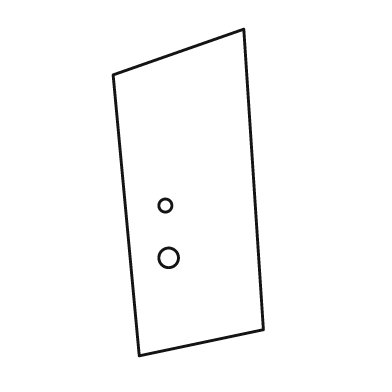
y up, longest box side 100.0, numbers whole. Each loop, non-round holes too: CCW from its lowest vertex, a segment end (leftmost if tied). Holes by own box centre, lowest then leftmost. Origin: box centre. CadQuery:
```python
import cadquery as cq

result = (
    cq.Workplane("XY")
    .moveTo(-15.0, -50.0)
    .lineTo(23.0, -42.0)
    .lineTo(17.0, 50.0)
    .lineTo(-23.0, 36.0)
    .close()
    .moveTo(-6.0, -20.0)
    .circle(3.0)
    .moveTo(-7.0, -4.0)
    .circle(2.0)
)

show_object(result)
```